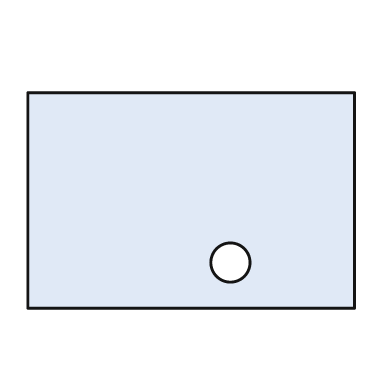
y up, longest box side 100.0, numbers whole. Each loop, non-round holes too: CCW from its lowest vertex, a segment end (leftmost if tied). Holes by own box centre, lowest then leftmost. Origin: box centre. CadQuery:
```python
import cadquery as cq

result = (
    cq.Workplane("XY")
    .moveTo(-50.0, -33.0)
    .lineTo(50.0, -33.0)
    .lineTo(50.0, 33.0)
    .lineTo(-50.0, 33.0)
    .close()
    .moveTo(12.0, -19.0)
    .circle(6.0)
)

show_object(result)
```